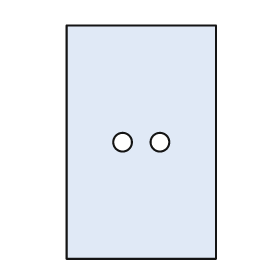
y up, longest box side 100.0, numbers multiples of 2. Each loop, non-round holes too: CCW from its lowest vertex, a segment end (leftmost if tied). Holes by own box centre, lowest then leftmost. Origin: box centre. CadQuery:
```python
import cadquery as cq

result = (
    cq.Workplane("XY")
    .moveTo(-32.0, -50.0)
    .lineTo(32.0, -50.0)
    .lineTo(32.0, 50.0)
    .lineTo(-32.0, 50.0)
    .close()
    .moveTo(-8.0, 0.0)
    .circle(4.0)
    .moveTo(8.0, 0.0)
    .circle(4.0)
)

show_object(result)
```